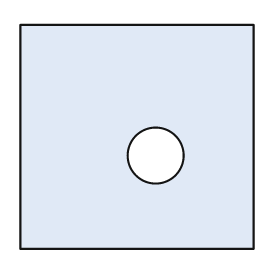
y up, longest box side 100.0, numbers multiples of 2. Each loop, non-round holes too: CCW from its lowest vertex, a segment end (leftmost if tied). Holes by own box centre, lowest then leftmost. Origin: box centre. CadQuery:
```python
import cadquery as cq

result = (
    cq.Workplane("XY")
    .moveTo(-50.0, -48.0)
    .lineTo(50.0, -48.0)
    .lineTo(50.0, 48.0)
    .lineTo(-50.0, 48.0)
    .close()
    .moveTo(8.0, -8.0)
    .circle(12.0)
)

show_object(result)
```